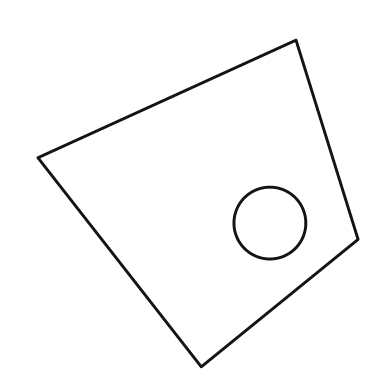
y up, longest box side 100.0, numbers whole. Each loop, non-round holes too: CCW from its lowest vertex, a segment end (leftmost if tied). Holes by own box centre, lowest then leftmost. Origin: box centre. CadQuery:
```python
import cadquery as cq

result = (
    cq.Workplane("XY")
    .moveTo(1.0, -50.0)
    .lineTo(49.0, -11.0)
    .lineTo(30.0, 50.0)
    .lineTo(-49.0, 14.0)
    .close()
    .moveTo(22.0, -6.0)
    .circle(11.0)
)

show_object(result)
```